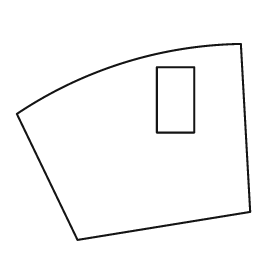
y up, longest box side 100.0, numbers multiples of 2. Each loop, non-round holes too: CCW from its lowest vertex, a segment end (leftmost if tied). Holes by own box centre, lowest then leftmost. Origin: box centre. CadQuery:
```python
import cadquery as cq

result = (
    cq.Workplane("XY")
    .moveTo(-24.0, -42.0)
    .lineTo(50.0, -30.0)
    .lineTo(46.0, 42.0)
    .threePointArc((-4.0, 34.0), (-50.0, 12.0))
    .close()
    .moveTo(10.0, 4.0)
    .lineTo(26.0, 4.0)
    .lineTo(26.0, 32.0)
    .lineTo(10.0, 32.0)
    .close()
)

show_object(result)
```